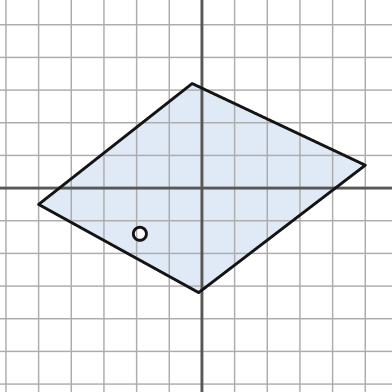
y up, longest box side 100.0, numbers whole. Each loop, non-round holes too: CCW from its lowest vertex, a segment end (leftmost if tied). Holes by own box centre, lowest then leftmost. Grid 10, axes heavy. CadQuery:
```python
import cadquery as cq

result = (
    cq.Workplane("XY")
    .moveTo(-1.0, -32.0)
    .lineTo(50.0, 7.0)
    .lineTo(-3.0, 32.0)
    .lineTo(-50.0, -5.0)
    .close()
    .moveTo(-19.0, -14.0)
    .circle(2.0)
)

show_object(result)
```